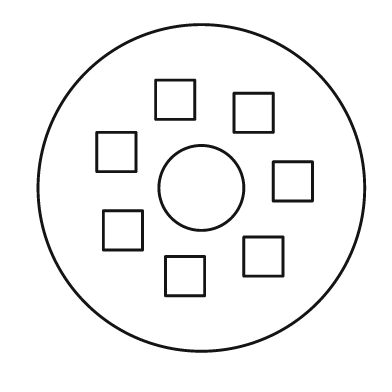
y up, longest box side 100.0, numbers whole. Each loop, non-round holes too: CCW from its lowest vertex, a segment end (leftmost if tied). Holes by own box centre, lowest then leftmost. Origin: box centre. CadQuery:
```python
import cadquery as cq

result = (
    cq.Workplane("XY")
    .moveTo(0.0, 0.0)
    .circle(50.0)
    .moveTo(-11.0, -33.0)
    .lineTo(1.0, -33.0)
    .lineTo(1.0, -21.0)
    .lineTo(-11.0, -21.0)
    .close()
    .moveTo(13.0, -27.0)
    .lineTo(25.0, -27.0)
    .lineTo(25.0, -15.0)
    .lineTo(13.0, -15.0)
    .close()
    .moveTo(-30.0, -19.0)
    .lineTo(-18.0, -19.0)
    .lineTo(-18.0, -7.0)
    .lineTo(-30.0, -7.0)
    .close()
    .moveTo(0.0, 0.0)
    .circle(13.0)
    .moveTo(22.0, -4.0)
    .lineTo(34.0, -4.0)
    .lineTo(34.0, 8.0)
    .lineTo(22.0, 8.0)
    .close()
    .moveTo(-32.0, 5.0)
    .lineTo(-20.0, 5.0)
    .lineTo(-20.0, 17.0)
    .lineTo(-32.0, 17.0)
    .close()
    .moveTo(10.0, 17.0)
    .lineTo(22.0, 17.0)
    .lineTo(22.0, 29.0)
    .lineTo(10.0, 29.0)
    .close()
    .moveTo(-14.0, 21.0)
    .lineTo(-2.0, 21.0)
    .lineTo(-2.0, 33.0)
    .lineTo(-14.0, 33.0)
    .close()
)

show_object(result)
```